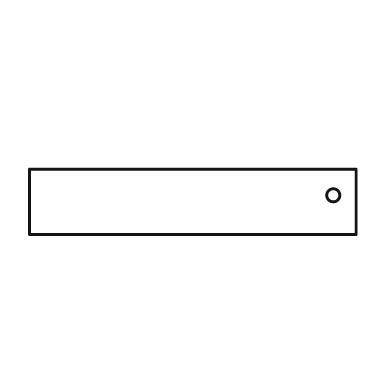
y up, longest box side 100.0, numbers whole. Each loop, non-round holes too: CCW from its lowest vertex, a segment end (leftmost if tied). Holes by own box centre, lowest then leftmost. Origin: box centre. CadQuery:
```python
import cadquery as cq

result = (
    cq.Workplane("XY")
    .moveTo(-50.0, -10.0)
    .lineTo(50.0, -10.0)
    .lineTo(50.0, 10.0)
    .lineTo(-50.0, 10.0)
    .close()
    .moveTo(43.0, 2.0)
    .circle(2.0)
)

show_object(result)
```